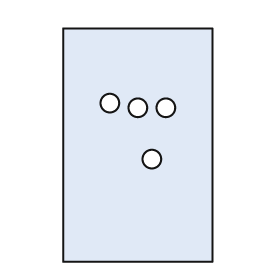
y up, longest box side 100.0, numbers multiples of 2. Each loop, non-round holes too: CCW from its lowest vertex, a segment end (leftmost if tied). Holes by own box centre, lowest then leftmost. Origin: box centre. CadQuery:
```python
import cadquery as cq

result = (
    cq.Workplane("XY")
    .moveTo(-32.0, -50.0)
    .lineTo(32.0, -50.0)
    .lineTo(32.0, 50.0)
    .lineTo(-32.0, 50.0)
    .close()
    .moveTo(6.0, -6.0)
    .circle(4.0)
    .moveTo(0.0, 16.0)
    .circle(4.0)
    .moveTo(12.0, 16.0)
    .circle(4.0)
    .moveTo(-12.0, 18.0)
    .circle(4.0)
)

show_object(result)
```